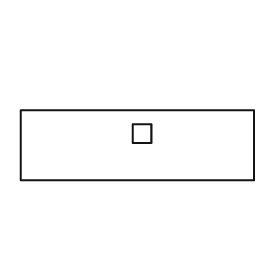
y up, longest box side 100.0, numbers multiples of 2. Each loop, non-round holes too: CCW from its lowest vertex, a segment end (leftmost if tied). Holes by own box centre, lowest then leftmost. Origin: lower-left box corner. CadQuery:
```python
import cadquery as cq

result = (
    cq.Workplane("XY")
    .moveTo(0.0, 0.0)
    .lineTo(100.0, 0.0)
    .lineTo(100.0, 30.0)
    .lineTo(0.0, 30.0)
    .close()
    .moveTo(48.0, 16.0)
    .lineTo(56.0, 16.0)
    .lineTo(56.0, 24.0)
    .lineTo(48.0, 24.0)
    .close()
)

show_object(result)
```